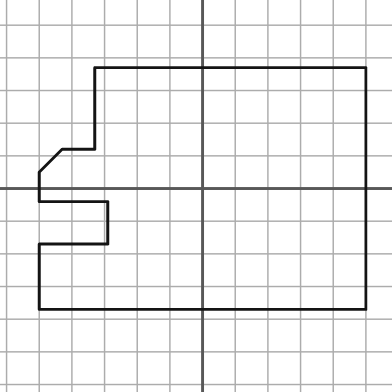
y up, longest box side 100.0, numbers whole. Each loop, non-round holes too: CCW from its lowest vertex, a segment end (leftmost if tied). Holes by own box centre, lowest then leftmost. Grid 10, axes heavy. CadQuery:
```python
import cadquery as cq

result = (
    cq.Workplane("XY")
    .moveTo(-50.0, -37.0)
    .lineTo(50.0, -37.0)
    .lineTo(50.0, 37.0)
    .lineTo(-33.0, 37.0)
    .lineTo(-33.0, 12.0)
    .lineTo(-43.0, 12.0)
    .lineTo(-50.0, 5.0)
    .lineTo(-50.0, -4.0)
    .lineTo(-29.0, -4.0)
    .lineTo(-29.0, -17.0)
    .lineTo(-50.0, -17.0)
    .close()
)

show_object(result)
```